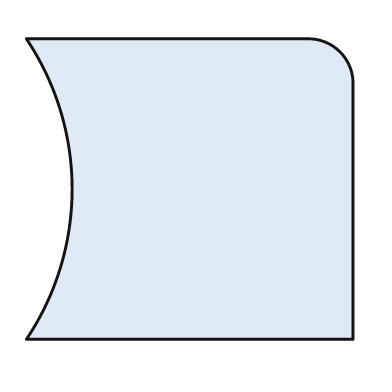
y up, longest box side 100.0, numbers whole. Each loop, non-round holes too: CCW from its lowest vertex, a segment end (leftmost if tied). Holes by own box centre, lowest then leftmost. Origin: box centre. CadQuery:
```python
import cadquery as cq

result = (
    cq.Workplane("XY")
    .moveTo(-50.0, -46.0)
    .lineTo(50.0, -46.0)
    .lineTo(50.0, 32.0)
    .threePointArc((46.0, 42.0), (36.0, 46.0))
    .lineTo(-50.0, 46.0)
    .threePointArc((-36.0, 0.0), (-50.0, -46.0))
    .close()
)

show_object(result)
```